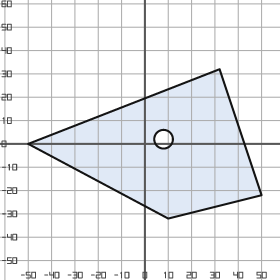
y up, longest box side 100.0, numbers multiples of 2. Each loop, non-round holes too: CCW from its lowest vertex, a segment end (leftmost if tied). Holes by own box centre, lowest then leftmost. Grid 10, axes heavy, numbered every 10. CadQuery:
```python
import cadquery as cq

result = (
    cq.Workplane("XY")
    .moveTo(10.0, -32.0)
    .lineTo(50.0, -22.0)
    .lineTo(32.0, 32.0)
    .lineTo(-50.0, 0.0)
    .close()
    .moveTo(8.0, 2.0)
    .circle(4.0)
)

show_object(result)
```